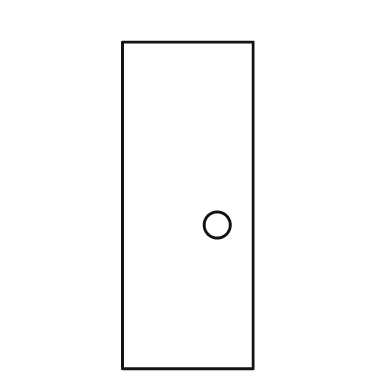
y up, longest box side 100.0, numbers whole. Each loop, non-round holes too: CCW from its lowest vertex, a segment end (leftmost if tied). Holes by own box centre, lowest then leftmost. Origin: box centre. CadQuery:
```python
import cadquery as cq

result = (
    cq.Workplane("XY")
    .moveTo(-20.0, -50.0)
    .lineTo(20.0, -50.0)
    .lineTo(20.0, 50.0)
    .lineTo(-20.0, 50.0)
    .close()
    .moveTo(9.0, -6.0)
    .circle(4.0)
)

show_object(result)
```